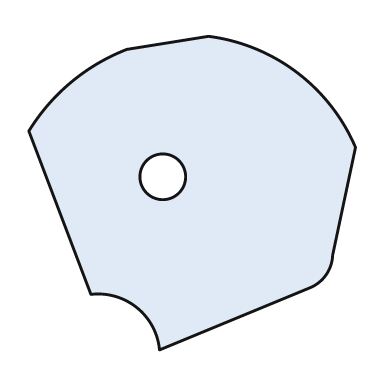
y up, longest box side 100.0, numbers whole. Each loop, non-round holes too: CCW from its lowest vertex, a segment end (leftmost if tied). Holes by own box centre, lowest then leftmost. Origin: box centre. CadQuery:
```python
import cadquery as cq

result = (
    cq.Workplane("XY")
    .moveTo(-10.0, -48.0)
    .lineTo(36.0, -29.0)
    .threePointArc((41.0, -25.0), (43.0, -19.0))
    .lineTo(50.0, 14.0)
    .threePointArc((32.0, 37.0), (5.0, 48.0))
    .lineTo(-20.0, 44.0)
    .threePointArc((-37.0, 34.0), (-50.0, 19.0))
    .lineTo(-31.0, -31.0)
    .threePointArc((-17.0, -35.0), (-10.0, -48.0))
    .close()
    .moveTo(-9.0, 5.0)
    .circle(7.0)
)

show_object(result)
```